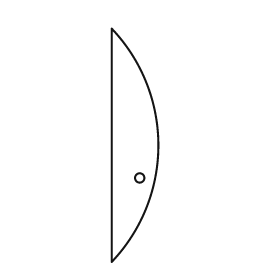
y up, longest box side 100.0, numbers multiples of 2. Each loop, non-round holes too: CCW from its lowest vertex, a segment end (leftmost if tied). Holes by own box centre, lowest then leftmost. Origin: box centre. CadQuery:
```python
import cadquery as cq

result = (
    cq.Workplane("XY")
    .moveTo(-10.0, -50.0)
    .threePointArc((10.0, 0.0), (-10.0, 50.0))
    .close()
    .moveTo(2.0, -14.0)
    .circle(2.0)
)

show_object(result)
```